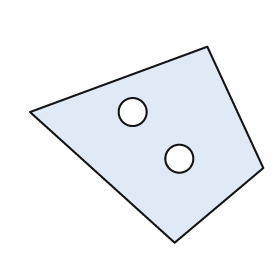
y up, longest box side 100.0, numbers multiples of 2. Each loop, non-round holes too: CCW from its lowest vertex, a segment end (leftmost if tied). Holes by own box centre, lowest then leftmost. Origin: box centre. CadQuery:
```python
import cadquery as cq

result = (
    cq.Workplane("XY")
    .moveTo(12.0, -42.0)
    .lineTo(50.0, -10.0)
    .lineTo(26.0, 42.0)
    .lineTo(-50.0, 14.0)
    .close()
    .moveTo(14.0, -6.0)
    .circle(6.0)
    .moveTo(-6.0, 14.0)
    .circle(6.0)
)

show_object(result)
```